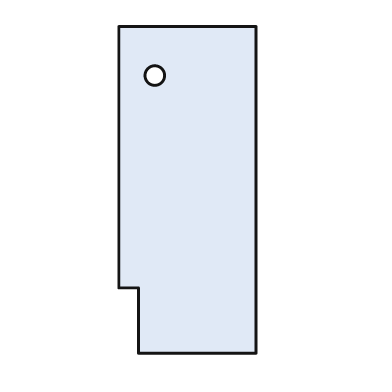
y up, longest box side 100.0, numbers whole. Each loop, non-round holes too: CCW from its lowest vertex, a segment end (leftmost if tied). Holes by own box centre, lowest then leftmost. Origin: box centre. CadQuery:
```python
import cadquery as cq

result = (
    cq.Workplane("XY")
    .moveTo(-15.0, -50.0)
    .lineTo(21.0, -50.0)
    .lineTo(21.0, 50.0)
    .lineTo(-21.0, 50.0)
    .lineTo(-21.0, -30.0)
    .lineTo(-15.0, -30.0)
    .close()
    .moveTo(-10.0, 35.0)
    .circle(3.0)
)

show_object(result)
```